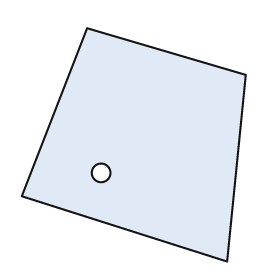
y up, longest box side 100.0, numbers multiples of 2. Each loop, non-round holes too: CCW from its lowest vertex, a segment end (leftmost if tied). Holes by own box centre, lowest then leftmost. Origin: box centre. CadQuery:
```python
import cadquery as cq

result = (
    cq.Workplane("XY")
    .moveTo(40.0, -50.0)
    .lineTo(48.0, 30.0)
    .lineTo(-20.0, 50.0)
    .lineTo(-48.0, -22.0)
    .close()
    .moveTo(-14.0, -12.0)
    .circle(4.0)
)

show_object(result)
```